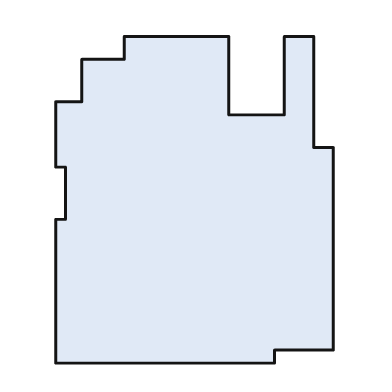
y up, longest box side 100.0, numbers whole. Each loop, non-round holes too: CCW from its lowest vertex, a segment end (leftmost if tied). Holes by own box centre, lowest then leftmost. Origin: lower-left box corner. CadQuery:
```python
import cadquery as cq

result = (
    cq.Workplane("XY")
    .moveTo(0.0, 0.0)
    .lineTo(67.0, 0.0)
    .lineTo(67.0, 4.0)
    .lineTo(85.0, 4.0)
    .lineTo(85.0, 66.0)
    .lineTo(79.0, 66.0)
    .lineTo(79.0, 100.0)
    .lineTo(70.0, 100.0)
    .lineTo(70.0, 76.0)
    .lineTo(53.0, 76.0)
    .lineTo(53.0, 100.0)
    .lineTo(21.0, 100.0)
    .lineTo(21.0, 93.0)
    .lineTo(8.0, 93.0)
    .lineTo(8.0, 80.0)
    .lineTo(0.0, 80.0)
    .lineTo(0.0, 60.0)
    .lineTo(3.0, 60.0)
    .lineTo(3.0, 44.0)
    .lineTo(0.0, 44.0)
    .close()
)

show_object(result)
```